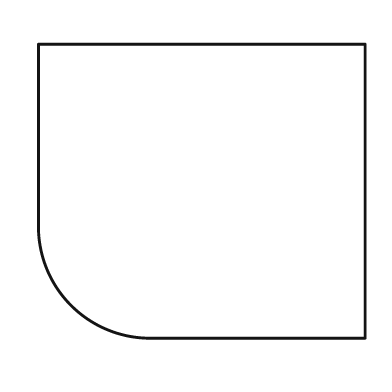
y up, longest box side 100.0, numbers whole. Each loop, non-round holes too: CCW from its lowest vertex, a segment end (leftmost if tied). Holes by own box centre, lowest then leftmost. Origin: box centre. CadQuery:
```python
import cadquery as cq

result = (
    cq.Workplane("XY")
    .moveTo(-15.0, -45.0)
    .lineTo(50.0, -45.0)
    .lineTo(50.0, 45.0)
    .lineTo(-50.0, 45.0)
    .lineTo(-50.0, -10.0)
    .threePointArc((-40.0, -35.0), (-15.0, -45.0))
    .close()
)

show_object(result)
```